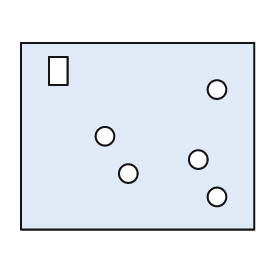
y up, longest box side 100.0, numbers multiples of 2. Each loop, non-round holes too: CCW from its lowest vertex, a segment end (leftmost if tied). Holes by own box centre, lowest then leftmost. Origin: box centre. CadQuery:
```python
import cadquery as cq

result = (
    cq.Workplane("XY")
    .moveTo(-50.0, -40.0)
    .lineTo(50.0, -40.0)
    .lineTo(50.0, 40.0)
    .lineTo(-50.0, 40.0)
    .close()
    .moveTo(34.0, -26.0)
    .circle(4.0)
    .moveTo(-4.0, -16.0)
    .circle(4.0)
    .moveTo(26.0, -10.0)
    .circle(4.0)
    .moveTo(-14.0, 0.0)
    .circle(4.0)
    .moveTo(34.0, 20.0)
    .circle(4.0)
    .moveTo(-38.0, 22.0)
    .lineTo(-30.0, 22.0)
    .lineTo(-30.0, 34.0)
    .lineTo(-38.0, 34.0)
    .close()
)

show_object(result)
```